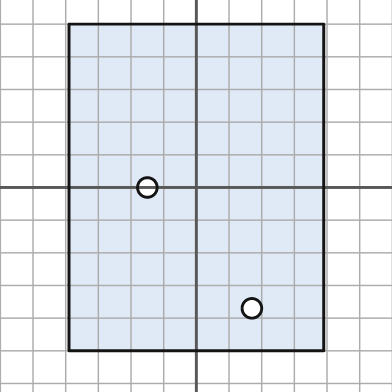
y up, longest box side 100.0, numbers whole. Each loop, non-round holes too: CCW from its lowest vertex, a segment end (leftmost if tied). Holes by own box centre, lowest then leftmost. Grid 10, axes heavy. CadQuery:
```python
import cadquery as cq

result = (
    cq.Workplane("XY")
    .moveTo(-39.0, -50.0)
    .lineTo(39.0, -50.0)
    .lineTo(39.0, 50.0)
    .lineTo(-39.0, 50.0)
    .close()
    .moveTo(17.0, -37.0)
    .circle(3.0)
    .moveTo(-15.0, 0.0)
    .circle(3.0)
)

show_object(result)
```